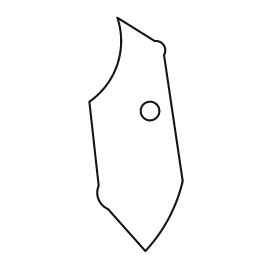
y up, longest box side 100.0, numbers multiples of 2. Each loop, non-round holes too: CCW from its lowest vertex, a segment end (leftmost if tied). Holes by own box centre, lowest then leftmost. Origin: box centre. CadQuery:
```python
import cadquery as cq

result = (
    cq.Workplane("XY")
    .moveTo(4.0, -50.0)
    .threePointArc((14.0, -36.0), (20.0, -20.0))
    .lineTo(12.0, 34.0)
    .threePointArc((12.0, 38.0), (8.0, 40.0))
    .lineTo(-8.0, 50.0)
    .threePointArc((-8.0, 30.0), (-20.0, 14.0))
    .lineTo(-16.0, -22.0)
    .threePointArc((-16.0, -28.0), (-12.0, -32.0))
    .close()
    .moveTo(6.0, 10.0)
    .circle(4.0)
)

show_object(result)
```